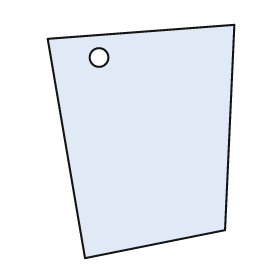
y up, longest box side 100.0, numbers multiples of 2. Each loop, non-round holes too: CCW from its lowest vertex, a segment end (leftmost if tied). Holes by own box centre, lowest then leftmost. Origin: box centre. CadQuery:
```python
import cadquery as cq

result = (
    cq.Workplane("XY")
    .moveTo(-24.0, -50.0)
    .lineTo(36.0, -38.0)
    .lineTo(40.0, 50.0)
    .lineTo(-40.0, 44.0)
    .close()
    .moveTo(-18.0, 36.0)
    .circle(4.0)
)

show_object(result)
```